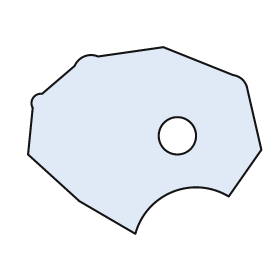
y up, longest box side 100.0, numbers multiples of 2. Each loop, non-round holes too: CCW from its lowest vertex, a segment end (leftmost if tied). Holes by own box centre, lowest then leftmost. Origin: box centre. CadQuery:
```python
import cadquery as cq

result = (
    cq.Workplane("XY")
    .moveTo(-4.0, -40.0)
    .threePointArc((12.0, -22.0), (36.0, -24.0))
    .lineTo(50.0, -4.0)
    .lineTo(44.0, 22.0)
    .threePointArc((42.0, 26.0), (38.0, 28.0))
    .lineTo(8.0, 40.0)
    .lineTo(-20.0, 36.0)
    .threePointArc((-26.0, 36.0), (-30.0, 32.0))
    .lineTo(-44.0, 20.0)
    .threePointArc((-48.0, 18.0), (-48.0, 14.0))
    .lineTo(-50.0, -6.0)
    .lineTo(-28.0, -26.0)
    .close()
    .moveTo(14.0, 2.0)
    .circle(8.0)
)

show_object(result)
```